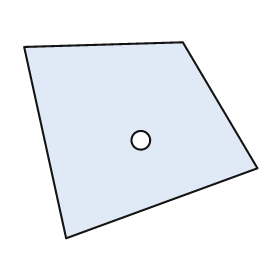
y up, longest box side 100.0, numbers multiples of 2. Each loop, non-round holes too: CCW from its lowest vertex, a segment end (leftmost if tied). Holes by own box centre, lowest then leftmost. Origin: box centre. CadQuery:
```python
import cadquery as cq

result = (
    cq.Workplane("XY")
    .moveTo(-32.0, -42.0)
    .lineTo(50.0, -12.0)
    .lineTo(18.0, 42.0)
    .lineTo(-50.0, 40.0)
    .close()
    .moveTo(0.0, 0.0)
    .circle(4.0)
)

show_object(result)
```